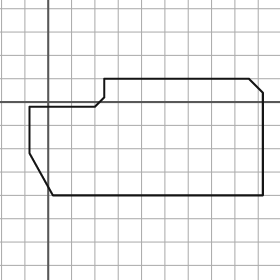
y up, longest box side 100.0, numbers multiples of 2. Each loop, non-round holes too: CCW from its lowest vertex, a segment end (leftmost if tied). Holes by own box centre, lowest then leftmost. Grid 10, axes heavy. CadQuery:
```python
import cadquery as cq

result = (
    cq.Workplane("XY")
    .moveTo(2.0, -40.0)
    .lineTo(92.0, -40.0)
    .lineTo(92.0, 4.0)
    .lineTo(86.0, 10.0)
    .lineTo(24.0, 10.0)
    .lineTo(24.0, 2.0)
    .lineTo(20.0, -2.0)
    .lineTo(-8.0, -2.0)
    .lineTo(-8.0, -22.0)
    .close()
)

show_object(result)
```